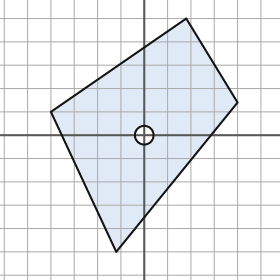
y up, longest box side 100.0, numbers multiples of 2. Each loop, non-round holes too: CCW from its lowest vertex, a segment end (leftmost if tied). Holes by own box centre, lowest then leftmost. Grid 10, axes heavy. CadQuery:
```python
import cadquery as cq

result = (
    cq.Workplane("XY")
    .moveTo(-12.0, -50.0)
    .lineTo(40.0, 14.0)
    .lineTo(18.0, 50.0)
    .lineTo(-40.0, 10.0)
    .close()
    .moveTo(0.0, 0.0)
    .circle(4.0)
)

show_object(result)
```